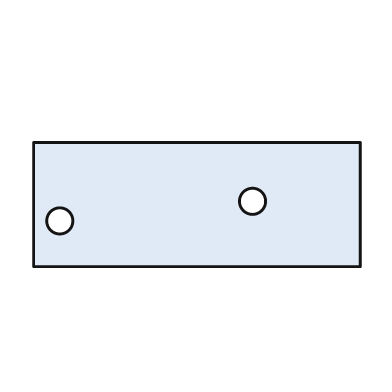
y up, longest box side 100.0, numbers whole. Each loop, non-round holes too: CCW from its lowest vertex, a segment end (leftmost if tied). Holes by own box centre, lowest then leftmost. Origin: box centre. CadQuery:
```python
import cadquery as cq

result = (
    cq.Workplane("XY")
    .moveTo(-50.0, -19.0)
    .lineTo(50.0, -19.0)
    .lineTo(50.0, 19.0)
    .lineTo(-50.0, 19.0)
    .close()
    .moveTo(-42.0, -5.0)
    .circle(4.0)
    .moveTo(17.0, 1.0)
    .circle(4.0)
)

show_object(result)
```